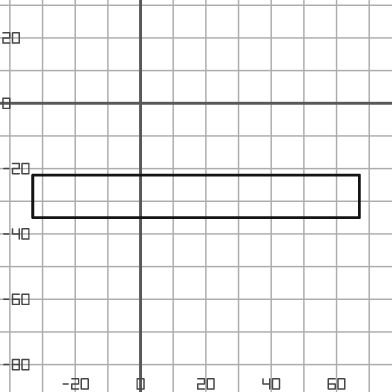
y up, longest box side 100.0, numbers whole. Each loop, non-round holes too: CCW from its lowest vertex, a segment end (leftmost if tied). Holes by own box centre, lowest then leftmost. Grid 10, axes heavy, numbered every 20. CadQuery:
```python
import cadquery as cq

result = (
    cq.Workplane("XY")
    .moveTo(-33.0, -35.0)
    .lineTo(67.0, -35.0)
    .lineTo(67.0, -22.0)
    .lineTo(-33.0, -22.0)
    .close()
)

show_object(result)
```